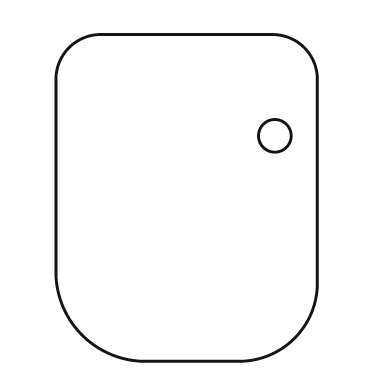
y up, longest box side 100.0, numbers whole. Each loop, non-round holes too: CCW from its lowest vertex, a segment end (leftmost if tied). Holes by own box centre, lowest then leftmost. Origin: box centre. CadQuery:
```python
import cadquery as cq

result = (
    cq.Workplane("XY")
    .moveTo(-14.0, -50.0)
    .lineTo(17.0, -50.0)
    .threePointArc((33.0, -43.0), (40.0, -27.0))
    .lineTo(40.0, 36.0)
    .threePointArc((36.0, 46.0), (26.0, 50.0))
    .lineTo(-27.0, 50.0)
    .threePointArc((-36.0, 46.0), (-40.0, 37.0))
    .lineTo(-40.0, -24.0)
    .threePointArc((-32.0, -42.0), (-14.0, -50.0))
    .close()
    .moveTo(27.0, 19.0)
    .circle(5.0)
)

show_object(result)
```